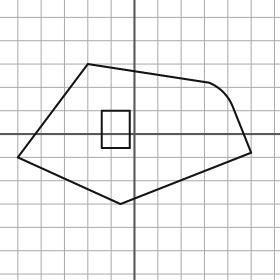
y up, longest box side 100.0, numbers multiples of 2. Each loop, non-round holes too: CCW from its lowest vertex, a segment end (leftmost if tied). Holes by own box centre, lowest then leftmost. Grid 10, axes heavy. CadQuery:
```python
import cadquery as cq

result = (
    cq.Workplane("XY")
    .moveTo(-6.0, -30.0)
    .lineTo(50.0, -8.0)
    .lineTo(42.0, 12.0)
    .threePointArc((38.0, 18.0), (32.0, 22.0))
    .lineTo(-20.0, 30.0)
    .lineTo(-50.0, -10.0)
    .close()
    .moveTo(-14.0, -6.0)
    .lineTo(-2.0, -6.0)
    .lineTo(-2.0, 10.0)
    .lineTo(-14.0, 10.0)
    .close()
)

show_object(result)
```